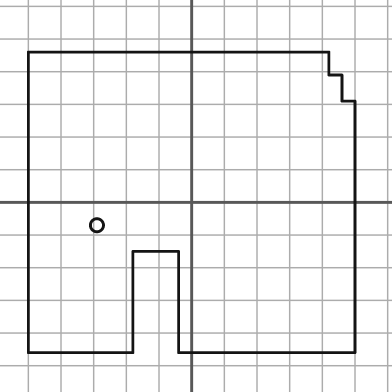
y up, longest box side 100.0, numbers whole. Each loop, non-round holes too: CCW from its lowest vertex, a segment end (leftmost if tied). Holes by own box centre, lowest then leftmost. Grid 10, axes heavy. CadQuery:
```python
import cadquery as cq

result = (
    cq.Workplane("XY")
    .moveTo(-50.0, -46.0)
    .lineTo(-18.0, -46.0)
    .lineTo(-18.0, -15.0)
    .lineTo(-4.0, -15.0)
    .lineTo(-4.0, -46.0)
    .lineTo(50.0, -46.0)
    .lineTo(50.0, 31.0)
    .lineTo(46.0, 31.0)
    .lineTo(46.0, 39.0)
    .lineTo(42.0, 39.0)
    .lineTo(42.0, 46.0)
    .lineTo(-50.0, 46.0)
    .close()
    .moveTo(-29.0, -7.0)
    .circle(2.0)
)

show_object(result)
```